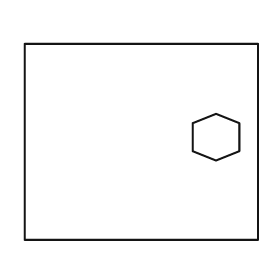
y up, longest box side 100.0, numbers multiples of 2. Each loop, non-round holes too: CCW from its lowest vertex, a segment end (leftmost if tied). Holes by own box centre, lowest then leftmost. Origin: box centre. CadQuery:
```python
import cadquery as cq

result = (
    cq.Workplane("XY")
    .moveTo(-50.0, -42.0)
    .lineTo(50.0, -42.0)
    .lineTo(50.0, 42.0)
    .lineTo(-50.0, 42.0)
    .close()
    .moveTo(32.0, -8.0)
    .lineTo(42.0, -4.0)
    .lineTo(42.0, 8.0)
    .lineTo(32.0, 12.0)
    .lineTo(22.0, 8.0)
    .lineTo(22.0, -4.0)
    .close()
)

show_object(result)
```